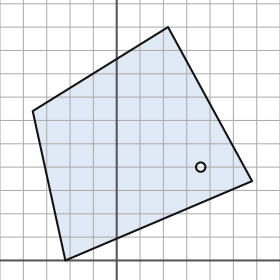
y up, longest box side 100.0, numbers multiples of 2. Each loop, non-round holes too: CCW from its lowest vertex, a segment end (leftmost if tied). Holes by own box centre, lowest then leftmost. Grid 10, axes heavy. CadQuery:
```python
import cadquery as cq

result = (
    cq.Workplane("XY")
    .moveTo(-22.0, 0.0)
    .lineTo(58.0, 34.0)
    .lineTo(22.0, 100.0)
    .lineTo(-36.0, 64.0)
    .close()
    .moveTo(36.0, 40.0)
    .circle(2.0)
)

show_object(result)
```